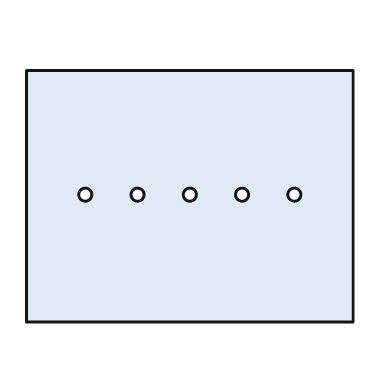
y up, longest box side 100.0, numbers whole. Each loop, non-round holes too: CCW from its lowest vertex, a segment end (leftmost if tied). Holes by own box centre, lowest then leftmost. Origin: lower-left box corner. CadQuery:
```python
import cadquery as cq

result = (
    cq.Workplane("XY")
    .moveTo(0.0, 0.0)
    .lineTo(100.0, 0.0)
    .lineTo(100.0, 77.0)
    .lineTo(0.0, 77.0)
    .close()
    .moveTo(18.0, 39.0)
    .circle(2.0)
    .moveTo(34.0, 39.0)
    .circle(2.0)
    .moveTo(50.0, 39.0)
    .circle(2.0)
    .moveTo(66.0, 39.0)
    .circle(2.0)
    .moveTo(82.0, 39.0)
    .circle(2.0)
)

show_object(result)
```